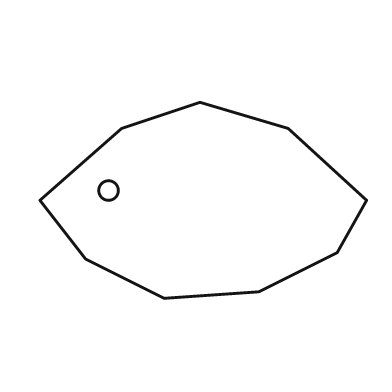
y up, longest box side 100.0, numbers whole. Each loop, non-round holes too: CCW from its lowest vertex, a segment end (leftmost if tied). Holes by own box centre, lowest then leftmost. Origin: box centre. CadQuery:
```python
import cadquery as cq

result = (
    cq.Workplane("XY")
    .moveTo(-12.0, -30.0)
    .lineTo(17.0, -28.0)
    .lineTo(41.0, -16.0)
    .lineTo(50.0, 0.0)
    .lineTo(26.0, 22.0)
    .lineTo(-1.0, 30.0)
    .lineTo(-25.0, 22.0)
    .lineTo(-50.0, 0.0)
    .lineTo(-36.0, -18.0)
    .close()
    .moveTo(-29.0, 3.0)
    .circle(3.0)
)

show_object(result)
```